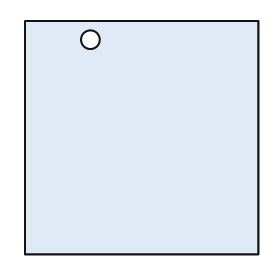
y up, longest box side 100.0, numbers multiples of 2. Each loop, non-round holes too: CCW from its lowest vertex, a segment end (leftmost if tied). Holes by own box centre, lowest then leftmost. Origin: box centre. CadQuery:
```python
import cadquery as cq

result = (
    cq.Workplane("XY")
    .moveTo(-50.0, -50.0)
    .lineTo(50.0, -50.0)
    .lineTo(50.0, 50.0)
    .lineTo(-50.0, 50.0)
    .close()
    .moveTo(-22.0, 42.0)
    .circle(4.0)
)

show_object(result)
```